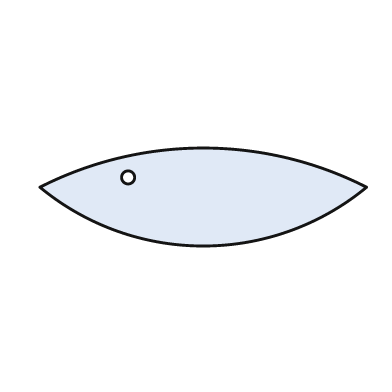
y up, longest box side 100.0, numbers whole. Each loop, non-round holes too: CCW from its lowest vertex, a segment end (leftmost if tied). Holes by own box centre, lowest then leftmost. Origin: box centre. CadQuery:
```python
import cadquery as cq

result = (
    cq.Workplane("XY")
    .moveTo(-50.0, 3.0)
    .threePointArc((0.0, -15.0), (50.0, 3.0))
    .threePointArc((0.0, 15.0), (-50.0, 3.0))
    .close()
    .moveTo(-23.0, 6.0)
    .circle(2.0)
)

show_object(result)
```